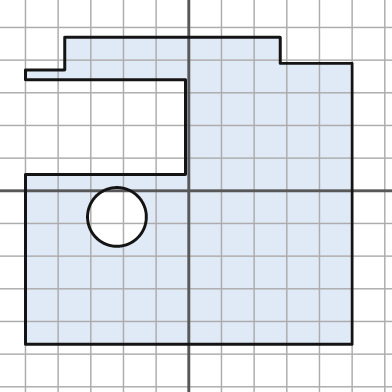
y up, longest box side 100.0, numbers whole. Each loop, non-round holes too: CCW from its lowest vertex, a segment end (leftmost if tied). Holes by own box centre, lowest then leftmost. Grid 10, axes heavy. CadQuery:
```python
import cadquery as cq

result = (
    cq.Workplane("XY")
    .moveTo(-50.0, -47.0)
    .lineTo(50.0, -47.0)
    .lineTo(50.0, 39.0)
    .lineTo(28.0, 39.0)
    .lineTo(28.0, 47.0)
    .lineTo(-38.0, 47.0)
    .lineTo(-38.0, 37.0)
    .lineTo(-50.0, 37.0)
    .lineTo(-50.0, 34.0)
    .lineTo(-1.0, 34.0)
    .lineTo(-1.0, 5.0)
    .lineTo(-50.0, 5.0)
    .close()
    .moveTo(-22.0, -8.0)
    .circle(9.0)
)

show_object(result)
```